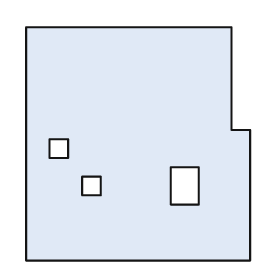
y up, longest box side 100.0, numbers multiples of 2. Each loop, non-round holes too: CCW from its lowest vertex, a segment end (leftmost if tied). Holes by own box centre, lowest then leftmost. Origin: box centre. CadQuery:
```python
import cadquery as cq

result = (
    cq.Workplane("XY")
    .moveTo(-48.0, -50.0)
    .lineTo(48.0, -50.0)
    .lineTo(48.0, 6.0)
    .lineTo(40.0, 6.0)
    .lineTo(40.0, 50.0)
    .lineTo(-48.0, 50.0)
    .close()
    .moveTo(-24.0, -22.0)
    .lineTo(-16.0, -22.0)
    .lineTo(-16.0, -14.0)
    .lineTo(-24.0, -14.0)
    .close()
    .moveTo(14.0, -26.0)
    .lineTo(26.0, -26.0)
    .lineTo(26.0, -10.0)
    .lineTo(14.0, -10.0)
    .close()
    .moveTo(-38.0, -6.0)
    .lineTo(-30.0, -6.0)
    .lineTo(-30.0, 2.0)
    .lineTo(-38.0, 2.0)
    .close()
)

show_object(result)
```